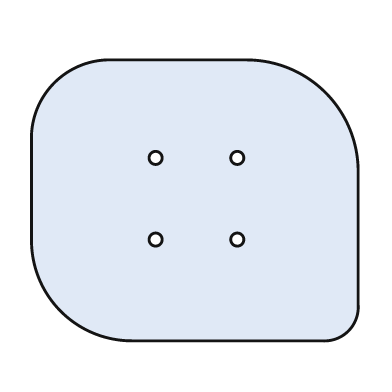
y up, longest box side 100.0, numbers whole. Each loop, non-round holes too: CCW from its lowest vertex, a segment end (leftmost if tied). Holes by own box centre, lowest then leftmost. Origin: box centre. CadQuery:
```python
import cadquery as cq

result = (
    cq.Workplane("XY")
    .moveTo(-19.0, -43.0)
    .lineTo(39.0, -43.0)
    .threePointArc((47.0, -40.0), (50.0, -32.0))
    .lineTo(50.0, 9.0)
    .threePointArc((40.0, 33.0), (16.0, 43.0))
    .lineTo(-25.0, 43.0)
    .threePointArc((-43.0, 36.0), (-50.0, 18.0))
    .lineTo(-50.0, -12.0)
    .threePointArc((-41.0, -34.0), (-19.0, -43.0))
    .close()
    .moveTo(-12.0, -12.0)
    .circle(2.0)
    .moveTo(13.0, -12.0)
    .circle(2.0)
    .moveTo(-12.0, 13.0)
    .circle(2.0)
    .moveTo(13.0, 13.0)
    .circle(2.0)
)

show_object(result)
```